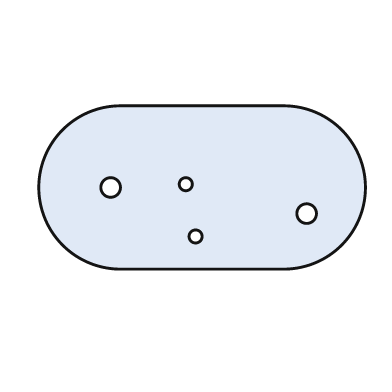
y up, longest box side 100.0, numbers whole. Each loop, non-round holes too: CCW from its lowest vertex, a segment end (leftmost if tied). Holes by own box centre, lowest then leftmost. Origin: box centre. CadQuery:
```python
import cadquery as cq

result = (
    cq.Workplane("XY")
    .moveTo(-25.0, -25.0)
    .lineTo(25.0, -25.0)
    .threePointArc((50.0, 0.0), (25.0, 25.0))
    .lineTo(-25.0, 25.0)
    .threePointArc((-50.0, 0.0), (-25.0, -25.0))
    .close()
    .moveTo(-2.0, -15.0)
    .circle(2.0)
    .moveTo(32.0, -8.0)
    .circle(3.0)
    .moveTo(-28.0, 0.0)
    .circle(3.0)
    .moveTo(-5.0, 1.0)
    .circle(2.0)
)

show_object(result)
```